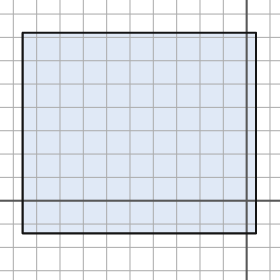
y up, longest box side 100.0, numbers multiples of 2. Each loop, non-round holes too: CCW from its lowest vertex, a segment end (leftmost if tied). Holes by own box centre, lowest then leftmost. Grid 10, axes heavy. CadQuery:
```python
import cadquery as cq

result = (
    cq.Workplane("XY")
    .moveTo(-96.0, -14.0)
    .lineTo(4.0, -14.0)
    .lineTo(4.0, 72.0)
    .lineTo(-96.0, 72.0)
    .close()
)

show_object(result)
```